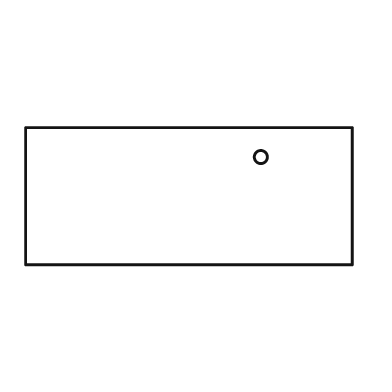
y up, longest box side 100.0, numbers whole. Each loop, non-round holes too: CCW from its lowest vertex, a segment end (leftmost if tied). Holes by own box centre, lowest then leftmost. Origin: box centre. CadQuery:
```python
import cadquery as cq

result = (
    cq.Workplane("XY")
    .moveTo(-50.0, -21.0)
    .lineTo(50.0, -21.0)
    .lineTo(50.0, 21.0)
    .lineTo(-50.0, 21.0)
    .close()
    .moveTo(22.0, 12.0)
    .circle(2.0)
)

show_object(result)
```